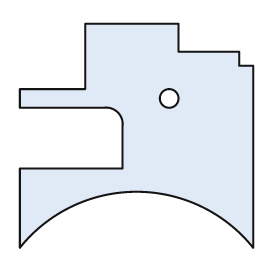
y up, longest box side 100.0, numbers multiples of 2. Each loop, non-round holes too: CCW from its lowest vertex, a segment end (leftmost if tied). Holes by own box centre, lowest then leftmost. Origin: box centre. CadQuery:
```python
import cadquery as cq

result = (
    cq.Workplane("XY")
    .moveTo(-50.0, -48.0)
    .threePointArc((0.0, -24.0), (50.0, -48.0))
    .lineTo(50.0, 30.0)
    .lineTo(44.0, 30.0)
    .lineTo(44.0, 36.0)
    .lineTo(18.0, 36.0)
    .lineTo(18.0, 48.0)
    .lineTo(-22.0, 48.0)
    .lineTo(-22.0, 20.0)
    .lineTo(-50.0, 20.0)
    .lineTo(-50.0, 12.0)
    .lineTo(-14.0, 12.0)
    .threePointArc((-8.0, 10.0), (-6.0, 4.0))
    .lineTo(-6.0, -14.0)
    .lineTo(-50.0, -14.0)
    .close()
    .moveTo(14.0, 16.0)
    .circle(4.0)
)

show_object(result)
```